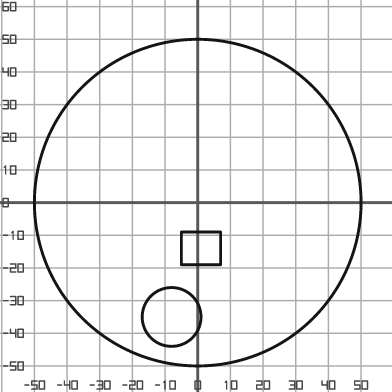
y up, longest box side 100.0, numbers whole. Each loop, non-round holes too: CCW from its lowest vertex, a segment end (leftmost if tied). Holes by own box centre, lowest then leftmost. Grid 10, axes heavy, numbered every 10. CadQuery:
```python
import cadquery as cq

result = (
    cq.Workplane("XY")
    .moveTo(0.0, 0.0)
    .circle(50.0)
    .moveTo(-8.0, -35.0)
    .circle(9.0)
    .moveTo(-5.0, -19.0)
    .lineTo(7.0, -19.0)
    .lineTo(7.0, -9.0)
    .lineTo(-5.0, -9.0)
    .close()
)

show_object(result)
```